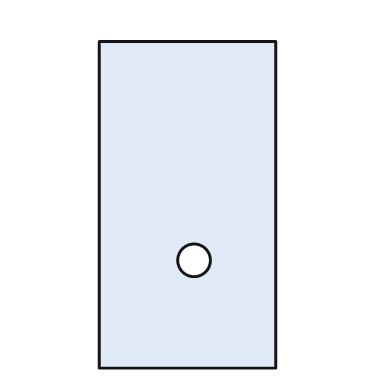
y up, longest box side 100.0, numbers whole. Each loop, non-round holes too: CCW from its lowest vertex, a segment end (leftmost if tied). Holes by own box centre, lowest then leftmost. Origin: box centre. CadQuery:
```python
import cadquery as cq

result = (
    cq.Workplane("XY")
    .moveTo(-27.0, -50.0)
    .lineTo(27.0, -50.0)
    .lineTo(27.0, 50.0)
    .lineTo(-27.0, 50.0)
    .close()
    .moveTo(2.0, -17.0)
    .circle(5.0)
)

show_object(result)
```